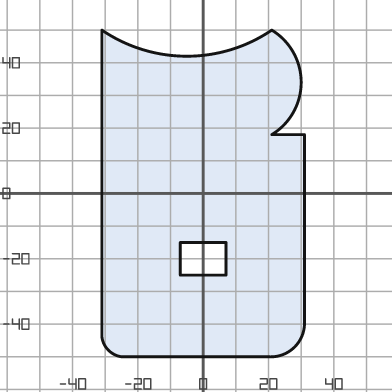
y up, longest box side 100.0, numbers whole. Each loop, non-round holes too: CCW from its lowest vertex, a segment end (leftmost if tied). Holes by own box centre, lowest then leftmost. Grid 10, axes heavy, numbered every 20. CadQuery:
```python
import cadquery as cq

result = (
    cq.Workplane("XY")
    .moveTo(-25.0, -50.0)
    .lineTo(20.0, -50.0)
    .threePointArc((28.0, -47.0), (31.0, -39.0))
    .lineTo(31.0, 18.0)
    .lineTo(21.0, 18.0)
    .threePointArc((30.0, 34.0), (21.0, 50.0))
    .threePointArc((-5.0, 42.0), (-31.0, 50.0))
    .lineTo(-31.0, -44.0)
    .threePointArc((-29.0, -48.0), (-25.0, -50.0))
    .close()
    .moveTo(-7.0, -25.0)
    .lineTo(7.0, -25.0)
    .lineTo(7.0, -15.0)
    .lineTo(-7.0, -15.0)
    .close()
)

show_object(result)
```